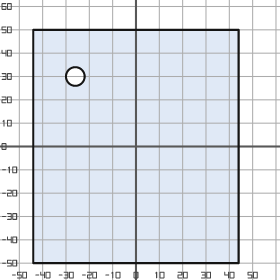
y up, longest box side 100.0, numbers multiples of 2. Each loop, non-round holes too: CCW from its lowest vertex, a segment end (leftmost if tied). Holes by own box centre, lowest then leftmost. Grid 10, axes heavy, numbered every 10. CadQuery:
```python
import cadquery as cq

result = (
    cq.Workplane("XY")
    .moveTo(-44.0, -50.0)
    .lineTo(44.0, -50.0)
    .lineTo(44.0, 50.0)
    .lineTo(-44.0, 50.0)
    .close()
    .moveTo(-26.0, 30.0)
    .circle(4.0)
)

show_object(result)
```